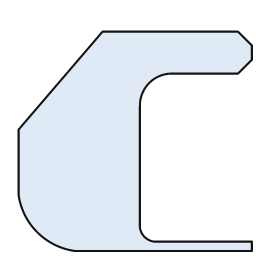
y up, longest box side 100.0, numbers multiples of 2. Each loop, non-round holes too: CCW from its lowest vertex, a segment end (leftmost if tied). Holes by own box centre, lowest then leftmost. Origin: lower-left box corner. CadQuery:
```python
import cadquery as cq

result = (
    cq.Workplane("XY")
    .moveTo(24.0, 0.0)
    .lineTo(100.0, 0.0)
    .lineTo(100.0, 4.0)
    .lineTo(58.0, 4.0)
    .threePointArc((54.0, 6.0), (52.0, 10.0))
    .lineTo(52.0, 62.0)
    .threePointArc((56.0, 72.0), (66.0, 76.0))
    .lineTo(94.0, 76.0)
    .lineTo(100.0, 82.0)
    .lineTo(100.0, 88.0)
    .lineTo(94.0, 94.0)
    .lineTo(36.0, 94.0)
    .lineTo(0.0, 52.0)
    .lineTo(0.0, 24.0)
    .threePointArc((8.0, 8.0), (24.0, 0.0))
    .close()
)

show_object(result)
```